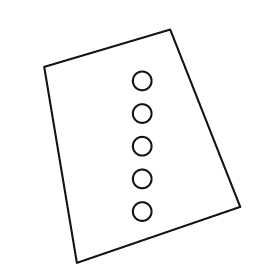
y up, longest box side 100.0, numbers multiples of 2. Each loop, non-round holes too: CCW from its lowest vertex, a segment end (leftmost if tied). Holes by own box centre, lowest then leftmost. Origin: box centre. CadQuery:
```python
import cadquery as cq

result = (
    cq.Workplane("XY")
    .moveTo(-28.0, -50.0)
    .lineTo(42.0, -26.0)
    .lineTo(12.0, 50.0)
    .lineTo(-42.0, 34.0)
    .close()
    .moveTo(0.0, -28.0)
    .circle(4.0)
    .moveTo(0.0, -14.0)
    .circle(4.0)
    .moveTo(0.0, 0.0)
    .circle(4.0)
    .moveTo(0.0, 14.0)
    .circle(4.0)
    .moveTo(0.0, 28.0)
    .circle(4.0)
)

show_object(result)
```